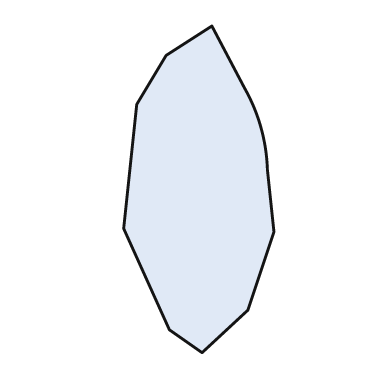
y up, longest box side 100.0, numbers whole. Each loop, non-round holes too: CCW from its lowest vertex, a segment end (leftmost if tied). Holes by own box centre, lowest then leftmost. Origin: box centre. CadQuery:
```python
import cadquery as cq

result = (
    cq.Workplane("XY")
    .moveTo(1.0, -50.0)
    .lineTo(15.0, -37.0)
    .lineTo(23.0, -13.0)
    .lineTo(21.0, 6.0)
    .threePointArc((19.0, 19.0), (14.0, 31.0))
    .lineTo(4.0, 50.0)
    .lineTo(-10.0, 41.0)
    .lineTo(-19.0, 26.0)
    .lineTo(-23.0, -12.0)
    .lineTo(-9.0, -43.0)
    .close()
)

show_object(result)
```